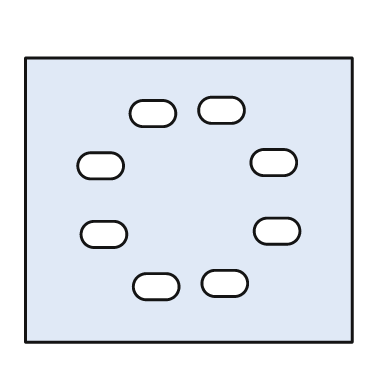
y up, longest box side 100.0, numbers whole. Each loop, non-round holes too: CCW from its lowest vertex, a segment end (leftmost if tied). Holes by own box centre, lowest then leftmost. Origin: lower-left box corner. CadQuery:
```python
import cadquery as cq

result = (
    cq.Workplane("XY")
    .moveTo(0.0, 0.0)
    .lineTo(100.0, 0.0)
    .lineTo(100.0, 87.0)
    .lineTo(0.0, 87.0)
    .close()
    .moveTo(37.0, 13.0)
    .lineTo(43.0, 13.0)
    .threePointArc((47.0, 17.0), (43.0, 21.0))
    .lineTo(37.0, 21.0)
    .threePointArc((33.0, 17.0), (37.0, 13.0))
    .close()
    .moveTo(58.0, 14.0)
    .lineTo(64.0, 14.0)
    .threePointArc((68.0, 18.0), (64.0, 22.0))
    .lineTo(58.0, 22.0)
    .threePointArc((54.0, 18.0), (58.0, 14.0))
    .close()
    .moveTo(21.0, 29.0)
    .lineTo(27.0, 29.0)
    .threePointArc((31.0, 33.0), (27.0, 37.0))
    .lineTo(21.0, 37.0)
    .threePointArc((17.0, 33.0), (21.0, 29.0))
    .close()
    .moveTo(74.0, 30.0)
    .lineTo(80.0, 30.0)
    .threePointArc((84.0, 34.0), (80.0, 38.0))
    .lineTo(74.0, 38.0)
    .threePointArc((70.0, 34.0), (74.0, 30.0))
    .close()
    .moveTo(20.0, 50.0)
    .lineTo(26.0, 50.0)
    .threePointArc((30.0, 54.0), (26.0, 58.0))
    .lineTo(20.0, 58.0)
    .threePointArc((16.0, 54.0), (20.0, 50.0))
    .close()
    .moveTo(73.0, 51.0)
    .lineTo(79.0, 51.0)
    .threePointArc((83.0, 55.0), (79.0, 59.0))
    .lineTo(73.0, 59.0)
    .threePointArc((69.0, 55.0), (73.0, 51.0))
    .close()
    .moveTo(36.0, 66.0)
    .lineTo(42.0, 66.0)
    .threePointArc((46.0, 70.0), (42.0, 74.0))
    .lineTo(36.0, 74.0)
    .threePointArc((32.0, 70.0), (36.0, 66.0))
    .close()
    .moveTo(57.0, 67.0)
    .lineTo(63.0, 67.0)
    .threePointArc((67.0, 71.0), (63.0, 75.0))
    .lineTo(57.0, 75.0)
    .threePointArc((53.0, 71.0), (57.0, 67.0))
    .close()
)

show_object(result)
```